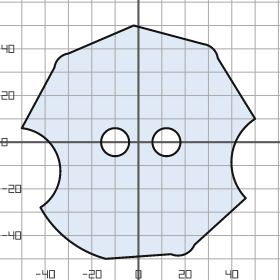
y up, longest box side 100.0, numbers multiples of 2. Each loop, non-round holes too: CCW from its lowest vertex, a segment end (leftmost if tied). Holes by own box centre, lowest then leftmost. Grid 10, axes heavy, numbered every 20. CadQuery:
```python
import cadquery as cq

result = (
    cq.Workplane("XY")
    .moveTo(-14.0, -50.0)
    .lineTo(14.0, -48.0)
    .threePointArc((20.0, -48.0), (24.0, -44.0))
    .lineTo(46.0, -24.0)
    .threePointArc((40.0, -6.0), (50.0, 10.0))
    .lineTo(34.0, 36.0)
    .threePointArc((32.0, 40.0), (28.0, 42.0))
    .lineTo(-2.0, 50.0)
    .lineTo(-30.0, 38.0)
    .threePointArc((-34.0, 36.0), (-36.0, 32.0))
    .lineTo(-50.0, 6.0)
    .threePointArc((-34.0, -8.0), (-42.0, -28.0))
    .threePointArc((-30.0, -42.0), (-14.0, -50.0))
    .close()
    .moveTo(-10.0, 0.0)
    .circle(6.0)
    .moveTo(12.0, 0.0)
    .circle(6.0)
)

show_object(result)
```